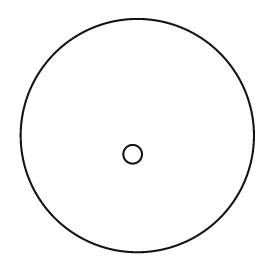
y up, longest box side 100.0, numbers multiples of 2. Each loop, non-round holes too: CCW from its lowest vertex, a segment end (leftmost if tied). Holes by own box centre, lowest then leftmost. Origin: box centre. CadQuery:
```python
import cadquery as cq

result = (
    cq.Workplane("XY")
    .moveTo(0.0, 0.0)
    .circle(50.0)
    .moveTo(-2.0, -8.0)
    .circle(4.0)
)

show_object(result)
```